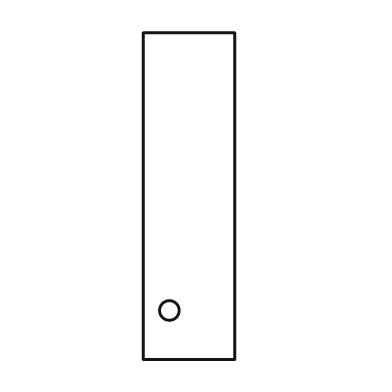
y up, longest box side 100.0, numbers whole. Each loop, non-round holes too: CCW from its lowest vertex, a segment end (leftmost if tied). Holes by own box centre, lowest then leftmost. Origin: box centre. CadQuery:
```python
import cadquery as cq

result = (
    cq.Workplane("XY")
    .moveTo(-14.0, -50.0)
    .lineTo(14.0, -50.0)
    .lineTo(14.0, 50.0)
    .lineTo(-14.0, 50.0)
    .close()
    .moveTo(-6.0, -35.0)
    .circle(3.0)
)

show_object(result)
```